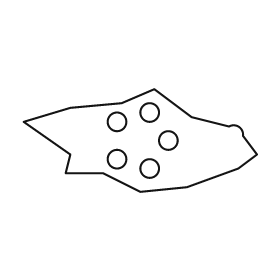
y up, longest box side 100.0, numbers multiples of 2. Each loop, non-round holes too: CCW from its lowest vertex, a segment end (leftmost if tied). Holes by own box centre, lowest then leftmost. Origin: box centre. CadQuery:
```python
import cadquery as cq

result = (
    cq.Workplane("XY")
    .moveTo(0.0, -22.0)
    .lineTo(20.0, -20.0)
    .lineTo(42.0, -12.0)
    .lineTo(50.0, -6.0)
    .lineTo(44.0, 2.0)
    .threePointArc((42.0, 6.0), (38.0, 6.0))
    .lineTo(22.0, 10.0)
    .lineTo(6.0, 22.0)
    .lineTo(-8.0, 16.0)
    .lineTo(-30.0, 14.0)
    .lineTo(-50.0, 8.0)
    .lineTo(-30.0, -6.0)
    .lineTo(-32.0, -14.0)
    .lineTo(-16.0, -14.0)
    .close()
    .moveTo(4.0, -12.0)
    .circle(4.0)
    .moveTo(-10.0, -8.0)
    .circle(4.0)
    .moveTo(12.0, 0.0)
    .circle(4.0)
    .moveTo(-10.0, 8.0)
    .circle(4.0)
    .moveTo(4.0, 12.0)
    .circle(4.0)
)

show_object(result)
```